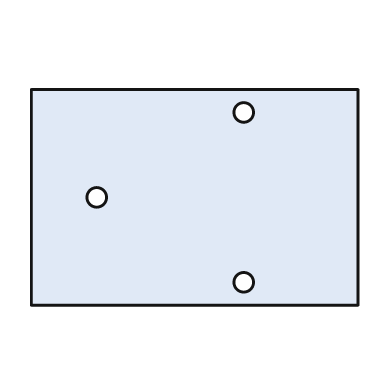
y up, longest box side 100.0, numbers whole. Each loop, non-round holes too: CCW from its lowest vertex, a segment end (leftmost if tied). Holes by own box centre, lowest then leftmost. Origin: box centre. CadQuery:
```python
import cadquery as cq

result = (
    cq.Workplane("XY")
    .moveTo(-50.0, -33.0)
    .lineTo(50.0, -33.0)
    .lineTo(50.0, 33.0)
    .lineTo(-50.0, 33.0)
    .close()
    .moveTo(15.0, -26.0)
    .circle(3.0)
    .moveTo(-30.0, 0.0)
    .circle(3.0)
    .moveTo(15.0, 26.0)
    .circle(3.0)
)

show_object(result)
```